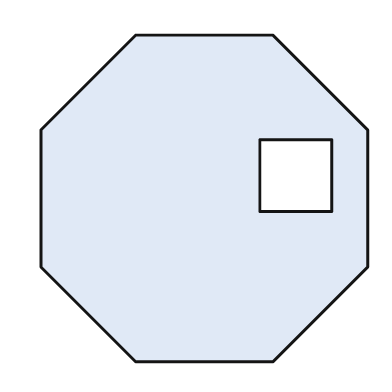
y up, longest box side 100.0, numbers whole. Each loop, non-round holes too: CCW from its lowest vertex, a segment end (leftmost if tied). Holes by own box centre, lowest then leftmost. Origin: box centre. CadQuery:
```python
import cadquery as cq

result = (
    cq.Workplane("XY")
    .moveTo(-21.0, -50.0)
    .lineTo(21.0, -50.0)
    .lineTo(50.0, -21.0)
    .lineTo(50.0, 21.0)
    .lineTo(21.0, 50.0)
    .lineTo(-21.0, 50.0)
    .lineTo(-50.0, 21.0)
    .lineTo(-50.0, -21.0)
    .close()
    .moveTo(17.0, -4.0)
    .lineTo(39.0, -4.0)
    .lineTo(39.0, 18.0)
    .lineTo(17.0, 18.0)
    .close()
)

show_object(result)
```